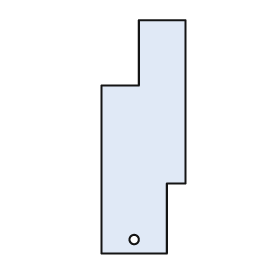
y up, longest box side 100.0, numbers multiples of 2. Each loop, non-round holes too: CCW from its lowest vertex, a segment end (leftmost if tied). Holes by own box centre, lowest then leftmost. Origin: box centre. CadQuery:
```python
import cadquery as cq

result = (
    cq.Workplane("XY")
    .moveTo(-18.0, -50.0)
    .lineTo(10.0, -50.0)
    .lineTo(10.0, -20.0)
    .lineTo(18.0, -20.0)
    .lineTo(18.0, 50.0)
    .lineTo(-2.0, 50.0)
    .lineTo(-2.0, 22.0)
    .lineTo(-18.0, 22.0)
    .close()
    .moveTo(-4.0, -44.0)
    .circle(2.0)
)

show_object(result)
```